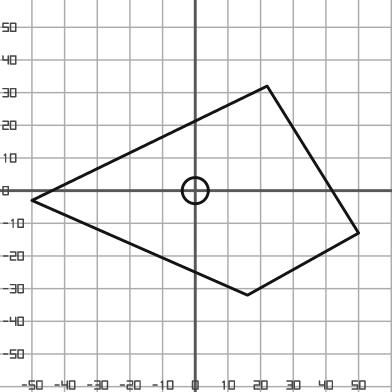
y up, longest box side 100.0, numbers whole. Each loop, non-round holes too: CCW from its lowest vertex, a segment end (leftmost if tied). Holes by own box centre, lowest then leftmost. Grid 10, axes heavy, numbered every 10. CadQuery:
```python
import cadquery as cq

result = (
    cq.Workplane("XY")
    .moveTo(16.0, -32.0)
    .lineTo(50.0, -13.0)
    .lineTo(22.0, 32.0)
    .lineTo(-50.0, -3.0)
    .close()
    .moveTo(0.0, 0.0)
    .circle(4.0)
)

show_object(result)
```